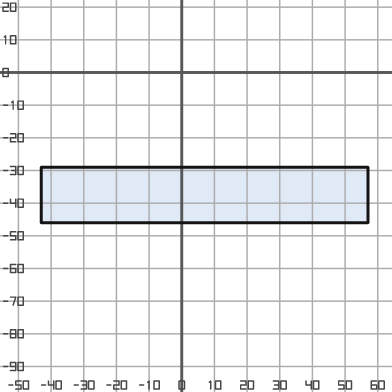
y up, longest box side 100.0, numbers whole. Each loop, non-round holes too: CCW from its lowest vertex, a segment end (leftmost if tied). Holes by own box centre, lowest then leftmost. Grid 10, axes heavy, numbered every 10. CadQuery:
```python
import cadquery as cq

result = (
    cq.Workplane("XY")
    .moveTo(-43.0, -46.0)
    .lineTo(57.0, -46.0)
    .lineTo(57.0, -29.0)
    .lineTo(-43.0, -29.0)
    .close()
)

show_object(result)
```